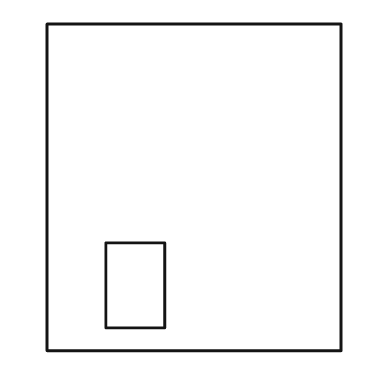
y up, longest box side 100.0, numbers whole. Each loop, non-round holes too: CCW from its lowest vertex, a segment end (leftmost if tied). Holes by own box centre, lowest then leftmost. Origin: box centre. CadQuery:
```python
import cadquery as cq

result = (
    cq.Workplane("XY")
    .moveTo(-45.0, -50.0)
    .lineTo(45.0, -50.0)
    .lineTo(45.0, 50.0)
    .lineTo(-45.0, 50.0)
    .close()
    .moveTo(-27.0, -43.0)
    .lineTo(-9.0, -43.0)
    .lineTo(-9.0, -17.0)
    .lineTo(-27.0, -17.0)
    .close()
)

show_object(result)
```